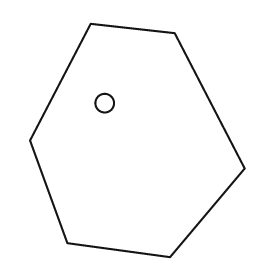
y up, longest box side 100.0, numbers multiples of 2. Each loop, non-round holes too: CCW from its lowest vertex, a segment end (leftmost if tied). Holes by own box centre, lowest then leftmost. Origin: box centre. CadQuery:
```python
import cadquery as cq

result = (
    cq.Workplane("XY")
    .moveTo(14.0, -50.0)
    .lineTo(46.0, -12.0)
    .lineTo(16.0, 46.0)
    .lineTo(-20.0, 50.0)
    .lineTo(-46.0, 0.0)
    .lineTo(-30.0, -44.0)
    .close()
    .moveTo(-14.0, 16.0)
    .circle(4.0)
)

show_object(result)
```